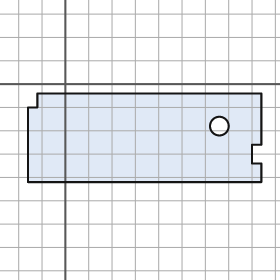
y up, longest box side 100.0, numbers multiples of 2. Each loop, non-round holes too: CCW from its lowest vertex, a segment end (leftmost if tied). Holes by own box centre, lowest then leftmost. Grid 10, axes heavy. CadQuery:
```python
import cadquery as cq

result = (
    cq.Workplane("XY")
    .moveTo(-16.0, -42.0)
    .lineTo(84.0, -42.0)
    .lineTo(84.0, -34.0)
    .lineTo(80.0, -34.0)
    .lineTo(80.0, -26.0)
    .lineTo(84.0, -26.0)
    .lineTo(84.0, -4.0)
    .lineTo(-12.0, -4.0)
    .lineTo(-12.0, -10.0)
    .lineTo(-16.0, -10.0)
    .close()
    .moveTo(66.0, -18.0)
    .circle(4.0)
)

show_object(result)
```